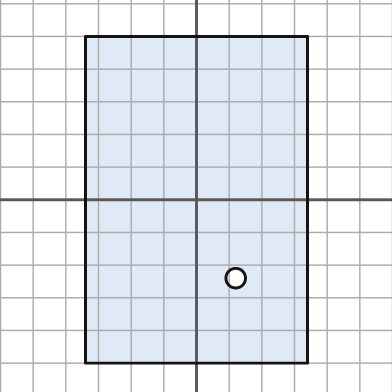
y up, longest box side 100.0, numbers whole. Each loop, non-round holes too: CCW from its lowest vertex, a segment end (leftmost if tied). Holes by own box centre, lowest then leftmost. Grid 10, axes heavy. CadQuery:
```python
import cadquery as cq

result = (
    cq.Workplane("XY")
    .moveTo(-34.0, -50.0)
    .lineTo(34.0, -50.0)
    .lineTo(34.0, 50.0)
    .lineTo(-34.0, 50.0)
    .close()
    .moveTo(12.0, -24.0)
    .circle(3.0)
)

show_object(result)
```